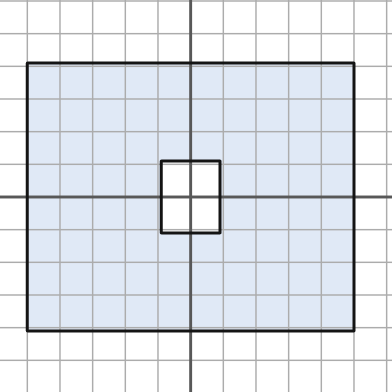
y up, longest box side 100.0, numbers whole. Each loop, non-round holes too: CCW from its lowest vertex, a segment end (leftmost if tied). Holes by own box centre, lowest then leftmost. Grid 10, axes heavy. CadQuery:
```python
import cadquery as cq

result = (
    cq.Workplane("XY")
    .moveTo(-50.0, -41.0)
    .lineTo(50.0, -41.0)
    .lineTo(50.0, 41.0)
    .lineTo(-50.0, 41.0)
    .close()
    .moveTo(-9.0, -11.0)
    .lineTo(9.0, -11.0)
    .lineTo(9.0, 11.0)
    .lineTo(-9.0, 11.0)
    .close()
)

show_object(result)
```